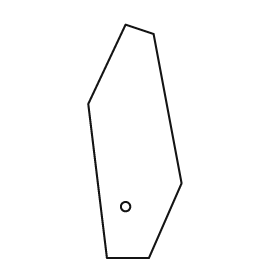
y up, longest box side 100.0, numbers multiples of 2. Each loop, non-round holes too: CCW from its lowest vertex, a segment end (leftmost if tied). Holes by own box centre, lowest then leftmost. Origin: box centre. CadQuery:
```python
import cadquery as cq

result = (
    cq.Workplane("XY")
    .moveTo(-12.0, -50.0)
    .lineTo(6.0, -50.0)
    .lineTo(20.0, -18.0)
    .lineTo(8.0, 46.0)
    .lineTo(-4.0, 50.0)
    .lineTo(-20.0, 16.0)
    .close()
    .moveTo(-4.0, -28.0)
    .circle(2.0)
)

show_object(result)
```